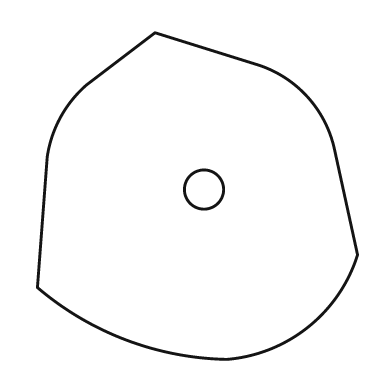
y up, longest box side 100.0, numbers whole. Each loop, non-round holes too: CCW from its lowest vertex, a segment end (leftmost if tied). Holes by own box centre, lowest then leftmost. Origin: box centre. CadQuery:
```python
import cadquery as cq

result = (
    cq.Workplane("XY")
    .moveTo(9.0, -50.0)
    .threePointArc((34.0, -40.0), (49.0, -18.0))
    .lineTo(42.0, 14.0)
    .threePointArc((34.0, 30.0), (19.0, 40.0))
    .lineTo(-13.0, 50.0)
    .lineTo(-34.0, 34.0)
    .threePointArc((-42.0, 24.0), (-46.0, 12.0))
    .lineTo(-49.0, -28.0)
    .threePointArc((-22.0, -44.0), (9.0, -50.0))
    .close()
    .moveTo(2.0, 2.0)
    .circle(6.0)
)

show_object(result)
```